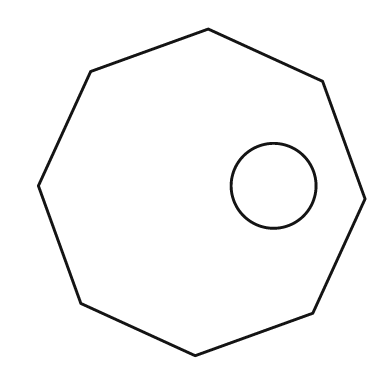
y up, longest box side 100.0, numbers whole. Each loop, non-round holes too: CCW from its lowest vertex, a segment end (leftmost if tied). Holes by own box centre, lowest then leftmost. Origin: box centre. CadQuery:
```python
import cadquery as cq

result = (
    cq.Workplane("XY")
    .moveTo(-2.0, -50.0)
    .lineTo(34.0, -37.0)
    .lineTo(50.0, -2.0)
    .lineTo(37.0, 34.0)
    .lineTo(2.0, 50.0)
    .lineTo(-34.0, 37.0)
    .lineTo(-50.0, 2.0)
    .lineTo(-37.0, -34.0)
    .close()
    .moveTo(22.0, 2.0)
    .circle(13.0)
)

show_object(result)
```